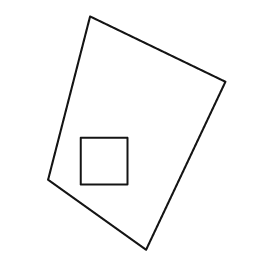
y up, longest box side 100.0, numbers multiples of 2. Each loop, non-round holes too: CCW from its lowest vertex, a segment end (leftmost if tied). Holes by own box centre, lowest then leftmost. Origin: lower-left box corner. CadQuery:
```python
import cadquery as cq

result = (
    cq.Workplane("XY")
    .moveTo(42.0, 0.0)
    .lineTo(76.0, 72.0)
    .lineTo(18.0, 100.0)
    .lineTo(0.0, 30.0)
    .close()
    .moveTo(14.0, 28.0)
    .lineTo(34.0, 28.0)
    .lineTo(34.0, 48.0)
    .lineTo(14.0, 48.0)
    .close()
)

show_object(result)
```